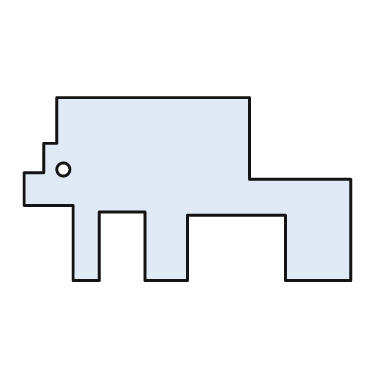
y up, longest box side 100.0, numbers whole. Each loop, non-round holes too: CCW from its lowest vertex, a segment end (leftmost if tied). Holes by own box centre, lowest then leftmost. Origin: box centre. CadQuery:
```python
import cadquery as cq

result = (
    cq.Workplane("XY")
    .moveTo(-35.0, -28.0)
    .lineTo(-27.0, -28.0)
    .lineTo(-27.0, -7.0)
    .lineTo(-13.0, -7.0)
    .lineTo(-13.0, -28.0)
    .lineTo(0.0, -28.0)
    .lineTo(0.0, -8.0)
    .lineTo(30.0, -8.0)
    .lineTo(30.0, -28.0)
    .lineTo(50.0, -28.0)
    .lineTo(50.0, 3.0)
    .lineTo(19.0, 3.0)
    .lineTo(19.0, 28.0)
    .lineTo(-40.0, 28.0)
    .lineTo(-40.0, 14.0)
    .lineTo(-44.0, 14.0)
    .lineTo(-44.0, 5.0)
    .lineTo(-50.0, 5.0)
    .lineTo(-50.0, -5.0)
    .lineTo(-35.0, -5.0)
    .close()
    .moveTo(-38.0, 6.0)
    .circle(2.0)
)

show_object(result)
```